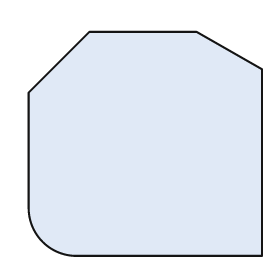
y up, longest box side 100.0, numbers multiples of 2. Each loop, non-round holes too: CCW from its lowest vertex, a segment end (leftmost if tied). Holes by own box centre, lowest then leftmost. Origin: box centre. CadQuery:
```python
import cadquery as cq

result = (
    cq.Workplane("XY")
    .moveTo(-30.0, -48.0)
    .lineTo(50.0, -48.0)
    .lineTo(50.0, 32.0)
    .lineTo(22.0, 48.0)
    .lineTo(-24.0, 48.0)
    .lineTo(-50.0, 22.0)
    .lineTo(-50.0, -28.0)
    .threePointArc((-44.0, -42.0), (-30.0, -48.0))
    .close()
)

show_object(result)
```